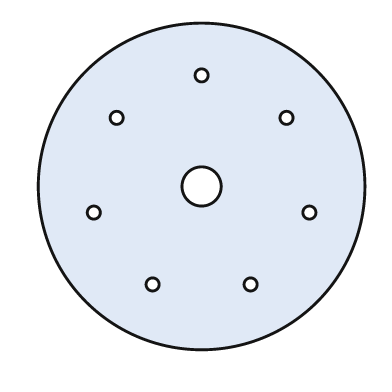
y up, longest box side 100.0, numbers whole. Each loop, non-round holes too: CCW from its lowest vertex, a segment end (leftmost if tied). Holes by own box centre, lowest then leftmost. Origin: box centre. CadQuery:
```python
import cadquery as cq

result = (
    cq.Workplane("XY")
    .moveTo(0.0, 0.0)
    .circle(50.0)
    .moveTo(-15.0, -30.0)
    .circle(2.0)
    .moveTo(15.0, -30.0)
    .circle(2.0)
    .moveTo(-33.0, -8.0)
    .circle(2.0)
    .moveTo(33.0, -8.0)
    .circle(2.0)
    .moveTo(0.0, 0.0)
    .circle(6.0)
    .moveTo(-26.0, 21.0)
    .circle(2.0)
    .moveTo(26.0, 21.0)
    .circle(2.0)
    .moveTo(0.0, 34.0)
    .circle(2.0)
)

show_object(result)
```